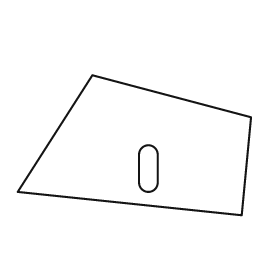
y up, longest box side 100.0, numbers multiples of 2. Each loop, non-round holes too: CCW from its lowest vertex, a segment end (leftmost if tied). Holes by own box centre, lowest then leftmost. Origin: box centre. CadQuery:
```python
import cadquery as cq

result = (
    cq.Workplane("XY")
    .moveTo(46.0, -30.0)
    .lineTo(50.0, 12.0)
    .lineTo(-18.0, 30.0)
    .lineTo(-50.0, -20.0)
    .close()
    .moveTo(2.0, -16.0)
    .threePointArc((6.0, -20.0), (10.0, -16.0))
    .lineTo(10.0, -4.0)
    .threePointArc((6.0, 0.0), (2.0, -4.0))
    .close()
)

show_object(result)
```